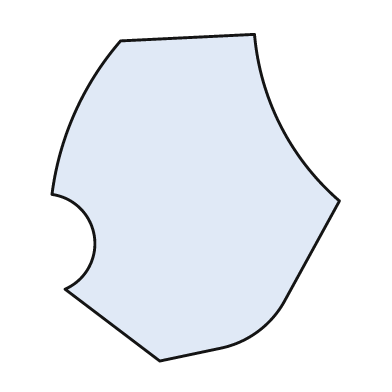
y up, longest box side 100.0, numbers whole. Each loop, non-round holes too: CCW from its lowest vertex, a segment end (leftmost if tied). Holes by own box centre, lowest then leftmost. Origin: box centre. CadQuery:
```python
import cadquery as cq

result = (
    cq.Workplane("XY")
    .moveTo(-11.0, -50.0)
    .lineTo(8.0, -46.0)
    .threePointArc((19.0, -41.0), (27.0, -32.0))
    .lineTo(44.0, -1.0)
    .threePointArc((26.0, 22.0), (18.0, 50.0))
    .lineTo(-23.0, 48.0)
    .threePointArc((-37.0, 26.0), (-44.0, 1.0))
    .threePointArc((-31.0, -12.0), (-40.0, -28.0))
    .close()
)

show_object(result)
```